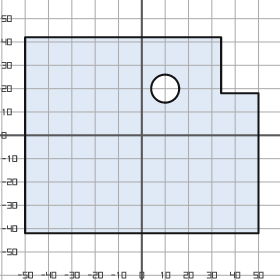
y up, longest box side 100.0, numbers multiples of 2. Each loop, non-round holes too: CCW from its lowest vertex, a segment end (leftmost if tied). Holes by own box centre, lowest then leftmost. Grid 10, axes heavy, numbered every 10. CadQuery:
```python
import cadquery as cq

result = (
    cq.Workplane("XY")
    .moveTo(-50.0, -42.0)
    .lineTo(50.0, -42.0)
    .lineTo(50.0, 18.0)
    .lineTo(34.0, 18.0)
    .lineTo(34.0, 42.0)
    .lineTo(-50.0, 42.0)
    .close()
    .moveTo(10.0, 20.0)
    .circle(6.0)
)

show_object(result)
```